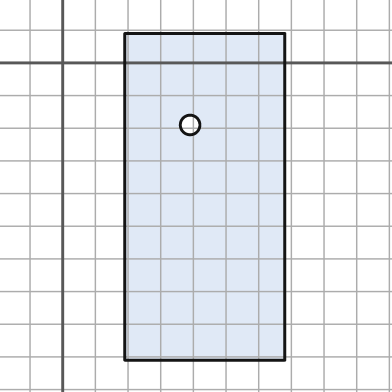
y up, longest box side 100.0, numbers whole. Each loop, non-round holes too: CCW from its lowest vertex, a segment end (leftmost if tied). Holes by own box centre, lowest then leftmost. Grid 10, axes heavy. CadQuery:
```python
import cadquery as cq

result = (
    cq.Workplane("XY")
    .moveTo(19.0, -91.0)
    .lineTo(68.0, -91.0)
    .lineTo(68.0, 9.0)
    .lineTo(19.0, 9.0)
    .close()
    .moveTo(39.0, -19.0)
    .circle(3.0)
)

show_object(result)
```